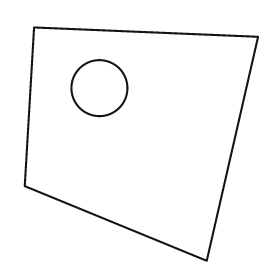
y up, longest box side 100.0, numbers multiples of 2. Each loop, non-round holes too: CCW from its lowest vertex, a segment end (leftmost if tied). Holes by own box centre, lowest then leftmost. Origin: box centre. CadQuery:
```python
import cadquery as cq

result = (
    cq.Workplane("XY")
    .moveTo(28.0, -50.0)
    .lineTo(50.0, 46.0)
    .lineTo(-46.0, 50.0)
    .lineTo(-50.0, -18.0)
    .close()
    .moveTo(-18.0, 24.0)
    .circle(12.0)
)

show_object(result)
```